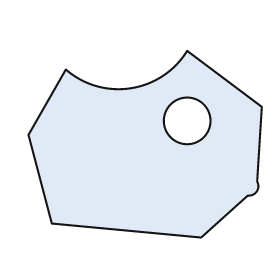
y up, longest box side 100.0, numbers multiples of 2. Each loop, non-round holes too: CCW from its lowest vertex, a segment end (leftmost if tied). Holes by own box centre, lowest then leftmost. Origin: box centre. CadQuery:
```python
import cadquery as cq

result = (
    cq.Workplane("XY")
    .moveTo(24.0, -40.0)
    .lineTo(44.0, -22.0)
    .threePointArc((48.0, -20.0), (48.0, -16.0))
    .lineTo(50.0, 16.0)
    .lineTo(18.0, 40.0)
    .threePointArc((-6.0, 24.0), (-34.0, 32.0))
    .lineTo(-50.0, 4.0)
    .lineTo(-40.0, -34.0)
    .close()
    .moveTo(18.0, 10.0)
    .circle(10.0)
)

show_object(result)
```